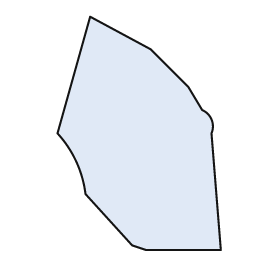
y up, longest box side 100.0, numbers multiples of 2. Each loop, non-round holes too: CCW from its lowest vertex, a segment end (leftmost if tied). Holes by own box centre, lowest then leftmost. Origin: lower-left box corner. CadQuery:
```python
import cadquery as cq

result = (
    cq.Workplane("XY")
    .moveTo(38.0, 0.0)
    .lineTo(70.0, 0.0)
    .lineTo(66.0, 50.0)
    .threePointArc((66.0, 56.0), (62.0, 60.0))
    .lineTo(56.0, 70.0)
    .lineTo(40.0, 86.0)
    .lineTo(14.0, 100.0)
    .lineTo(0.0, 50.0)
    .threePointArc((8.0, 38.0), (12.0, 24.0))
    .lineTo(32.0, 2.0)
    .close()
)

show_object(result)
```